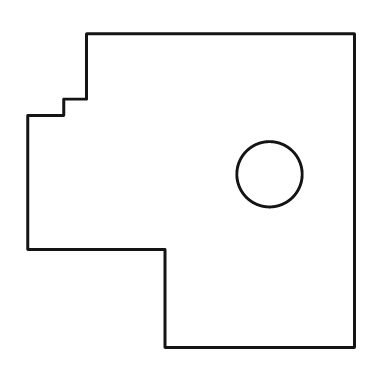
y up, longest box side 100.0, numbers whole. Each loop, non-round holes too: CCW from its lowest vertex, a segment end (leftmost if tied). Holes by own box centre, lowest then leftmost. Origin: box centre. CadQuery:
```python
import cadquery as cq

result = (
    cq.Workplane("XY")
    .moveTo(-8.0, -48.0)
    .lineTo(50.0, -48.0)
    .lineTo(50.0, 48.0)
    .lineTo(-32.0, 48.0)
    .lineTo(-32.0, 28.0)
    .lineTo(-39.0, 28.0)
    .lineTo(-39.0, 23.0)
    .lineTo(-50.0, 23.0)
    .lineTo(-50.0, -18.0)
    .lineTo(-8.0, -18.0)
    .close()
    .moveTo(24.0, 5.0)
    .circle(10.0)
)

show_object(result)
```